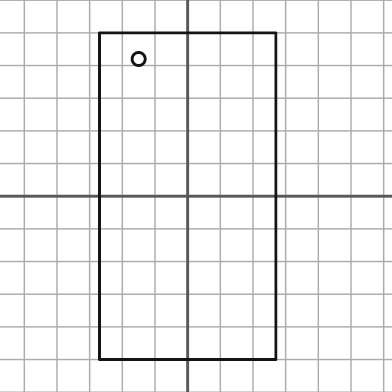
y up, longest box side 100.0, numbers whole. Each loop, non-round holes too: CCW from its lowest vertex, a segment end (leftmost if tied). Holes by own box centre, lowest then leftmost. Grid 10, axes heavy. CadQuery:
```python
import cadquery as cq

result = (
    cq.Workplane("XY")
    .moveTo(-27.0, -50.0)
    .lineTo(27.0, -50.0)
    .lineTo(27.0, 50.0)
    .lineTo(-27.0, 50.0)
    .close()
    .moveTo(-15.0, 42.0)
    .circle(2.0)
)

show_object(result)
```